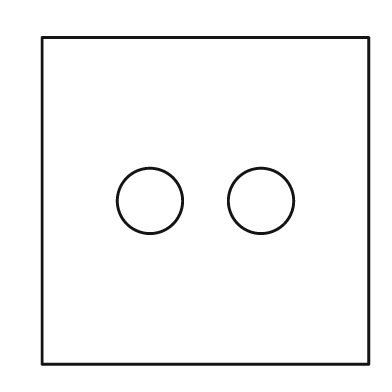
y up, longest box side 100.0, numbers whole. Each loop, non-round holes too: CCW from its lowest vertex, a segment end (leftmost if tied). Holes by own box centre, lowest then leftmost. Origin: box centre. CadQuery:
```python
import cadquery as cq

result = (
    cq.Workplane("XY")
    .moveTo(-50.0, -50.0)
    .lineTo(50.0, -50.0)
    .lineTo(50.0, 50.0)
    .lineTo(-50.0, 50.0)
    .close()
    .moveTo(-17.0, 0.0)
    .circle(10.0)
    .moveTo(17.0, 0.0)
    .circle(10.0)
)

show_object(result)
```